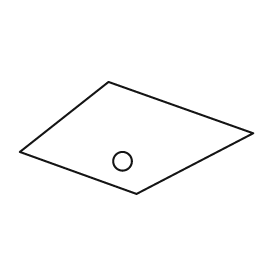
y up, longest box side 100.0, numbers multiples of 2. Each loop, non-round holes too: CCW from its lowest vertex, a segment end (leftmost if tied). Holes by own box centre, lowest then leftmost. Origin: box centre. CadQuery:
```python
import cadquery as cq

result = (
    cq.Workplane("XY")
    .moveTo(0.0, -24.0)
    .lineTo(50.0, 2.0)
    .lineTo(-12.0, 24.0)
    .lineTo(-50.0, -6.0)
    .close()
    .moveTo(-6.0, -10.0)
    .circle(4.0)
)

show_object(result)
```